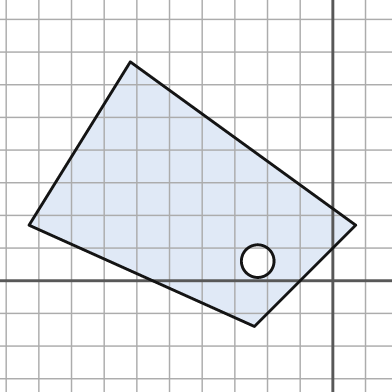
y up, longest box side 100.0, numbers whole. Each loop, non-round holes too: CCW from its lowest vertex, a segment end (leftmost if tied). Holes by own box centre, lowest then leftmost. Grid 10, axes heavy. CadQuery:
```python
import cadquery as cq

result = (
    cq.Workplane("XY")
    .moveTo(-24.0, -14.0)
    .lineTo(7.0, 17.0)
    .lineTo(-62.0, 67.0)
    .lineTo(-93.0, 17.0)
    .close()
    .moveTo(-23.0, 6.0)
    .circle(5.0)
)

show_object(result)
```